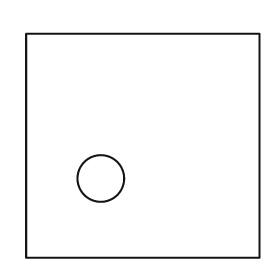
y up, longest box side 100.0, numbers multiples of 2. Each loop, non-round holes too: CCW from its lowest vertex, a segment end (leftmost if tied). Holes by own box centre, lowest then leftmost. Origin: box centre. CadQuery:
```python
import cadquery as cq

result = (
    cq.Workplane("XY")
    .moveTo(-50.0, -48.0)
    .lineTo(50.0, -48.0)
    .lineTo(50.0, 48.0)
    .lineTo(-50.0, 48.0)
    .close()
    .moveTo(-18.0, -14.0)
    .circle(10.0)
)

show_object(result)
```